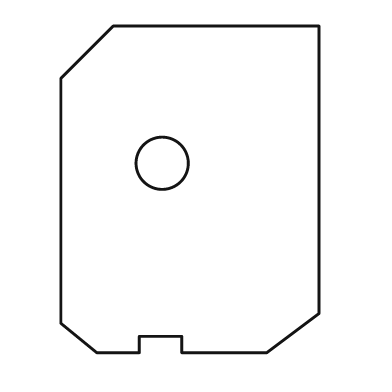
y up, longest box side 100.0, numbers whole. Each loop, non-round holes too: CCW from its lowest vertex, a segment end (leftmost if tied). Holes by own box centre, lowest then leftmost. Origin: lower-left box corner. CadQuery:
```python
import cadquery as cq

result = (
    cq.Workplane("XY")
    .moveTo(11.0, 0.0)
    .lineTo(24.0, 0.0)
    .lineTo(24.0, 5.0)
    .lineTo(37.0, 5.0)
    .lineTo(37.0, 0.0)
    .lineTo(63.0, 0.0)
    .lineTo(79.0, 12.0)
    .lineTo(79.0, 100.0)
    .lineTo(16.0, 100.0)
    .lineTo(0.0, 84.0)
    .lineTo(0.0, 9.0)
    .close()
    .moveTo(31.0, 58.0)
    .circle(8.0)
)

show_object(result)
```